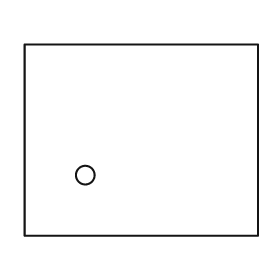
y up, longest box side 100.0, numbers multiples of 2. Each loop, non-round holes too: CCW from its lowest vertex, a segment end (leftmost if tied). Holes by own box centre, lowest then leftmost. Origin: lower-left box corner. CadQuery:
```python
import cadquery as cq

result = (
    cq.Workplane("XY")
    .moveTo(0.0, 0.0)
    .lineTo(100.0, 0.0)
    .lineTo(100.0, 82.0)
    .lineTo(0.0, 82.0)
    .close()
    .moveTo(26.0, 26.0)
    .circle(4.0)
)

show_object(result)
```